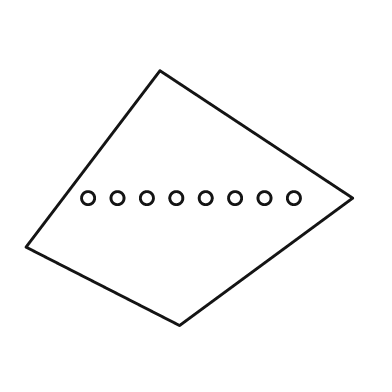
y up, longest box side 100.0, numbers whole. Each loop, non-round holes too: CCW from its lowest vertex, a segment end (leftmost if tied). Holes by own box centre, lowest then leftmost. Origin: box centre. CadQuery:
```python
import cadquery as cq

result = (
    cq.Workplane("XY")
    .moveTo(-3.0, -39.0)
    .lineTo(50.0, 0.0)
    .lineTo(-9.0, 39.0)
    .lineTo(-50.0, -15.0)
    .close()
    .moveTo(-31.0, 0.0)
    .circle(2.0)
    .moveTo(-22.0, 0.0)
    .circle(2.0)
    .moveTo(-13.0, 0.0)
    .circle(2.0)
    .moveTo(-4.0, 0.0)
    .circle(2.0)
    .moveTo(5.0, 0.0)
    .circle(2.0)
    .moveTo(14.0, 0.0)
    .circle(2.0)
    .moveTo(23.0, 0.0)
    .circle(2.0)
    .moveTo(32.0, 0.0)
    .circle(2.0)
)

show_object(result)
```